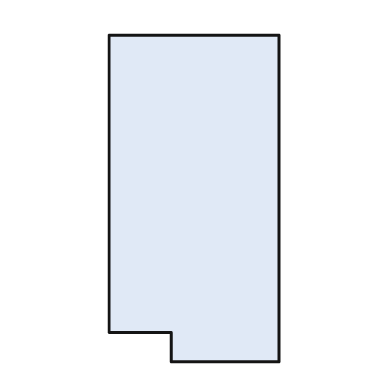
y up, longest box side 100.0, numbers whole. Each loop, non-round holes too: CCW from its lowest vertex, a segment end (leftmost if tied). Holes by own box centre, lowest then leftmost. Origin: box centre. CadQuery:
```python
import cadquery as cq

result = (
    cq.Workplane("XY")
    .moveTo(-7.0, -50.0)
    .lineTo(26.0, -50.0)
    .lineTo(26.0, 50.0)
    .lineTo(-26.0, 50.0)
    .lineTo(-26.0, -41.0)
    .lineTo(-7.0, -41.0)
    .close()
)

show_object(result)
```